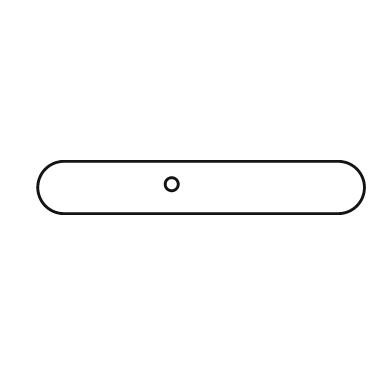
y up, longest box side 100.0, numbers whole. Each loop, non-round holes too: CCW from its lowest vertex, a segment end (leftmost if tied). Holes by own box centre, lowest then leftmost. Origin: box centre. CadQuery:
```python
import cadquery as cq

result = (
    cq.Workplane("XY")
    .moveTo(-42.0, -8.0)
    .lineTo(42.0, -8.0)
    .threePointArc((50.0, 0.0), (42.0, 8.0))
    .lineTo(-42.0, 8.0)
    .threePointArc((-50.0, 0.0), (-42.0, -8.0))
    .close()
    .moveTo(-9.0, 1.0)
    .circle(2.0)
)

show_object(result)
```